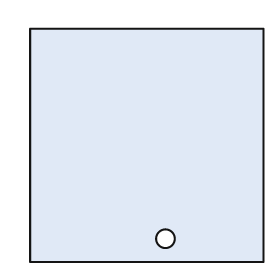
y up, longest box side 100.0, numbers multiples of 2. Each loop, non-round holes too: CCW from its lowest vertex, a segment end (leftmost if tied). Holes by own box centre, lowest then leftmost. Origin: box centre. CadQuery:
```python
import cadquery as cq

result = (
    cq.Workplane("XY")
    .moveTo(-50.0, -50.0)
    .lineTo(50.0, -50.0)
    .lineTo(50.0, 50.0)
    .lineTo(-50.0, 50.0)
    .close()
    .moveTo(8.0, -40.0)
    .circle(4.0)
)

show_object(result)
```